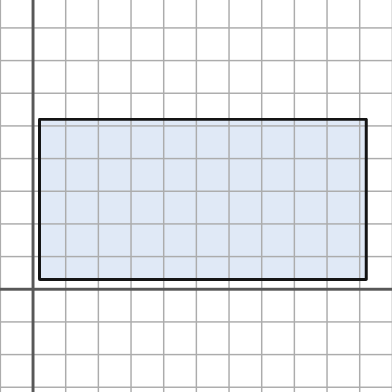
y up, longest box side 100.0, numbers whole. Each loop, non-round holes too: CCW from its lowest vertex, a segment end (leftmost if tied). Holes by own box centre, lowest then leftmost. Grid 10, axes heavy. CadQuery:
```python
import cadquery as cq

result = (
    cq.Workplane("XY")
    .moveTo(2.0, 3.0)
    .lineTo(102.0, 3.0)
    .lineTo(102.0, 52.0)
    .lineTo(2.0, 52.0)
    .close()
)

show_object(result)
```